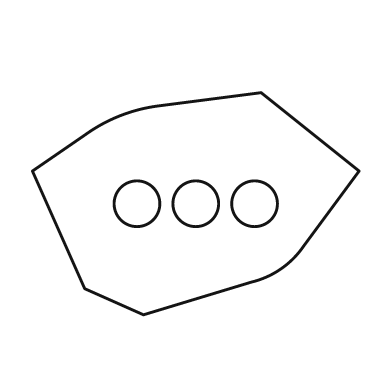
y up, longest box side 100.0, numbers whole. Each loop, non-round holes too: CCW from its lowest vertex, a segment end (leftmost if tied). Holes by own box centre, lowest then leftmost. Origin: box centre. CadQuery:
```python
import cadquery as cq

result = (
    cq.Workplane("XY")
    .moveTo(-16.0, -34.0)
    .lineTo(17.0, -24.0)
    .threePointArc((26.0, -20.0), (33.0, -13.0))
    .lineTo(50.0, 10.0)
    .lineTo(20.0, 34.0)
    .lineTo(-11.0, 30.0)
    .threePointArc((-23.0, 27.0), (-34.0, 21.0))
    .lineTo(-50.0, 10.0)
    .lineTo(-34.0, -26.0)
    .close()
    .moveTo(-18.0, 0.0)
    .circle(7.0)
    .moveTo(0.0, 0.0)
    .circle(7.0)
    .moveTo(18.0, 0.0)
    .circle(7.0)
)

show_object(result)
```